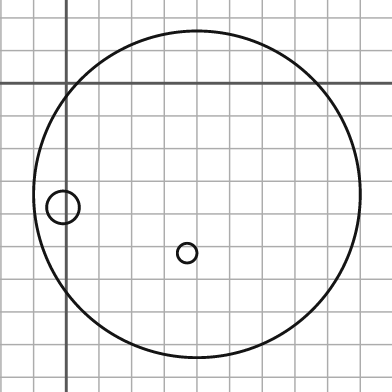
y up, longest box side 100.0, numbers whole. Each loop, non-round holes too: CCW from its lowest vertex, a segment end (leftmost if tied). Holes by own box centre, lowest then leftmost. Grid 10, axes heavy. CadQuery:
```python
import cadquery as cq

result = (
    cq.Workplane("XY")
    .moveTo(40.0, -34.0)
    .circle(50.0)
    .moveTo(37.0, -52.0)
    .circle(3.0)
    .moveTo(-1.0, -38.0)
    .circle(5.0)
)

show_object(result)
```